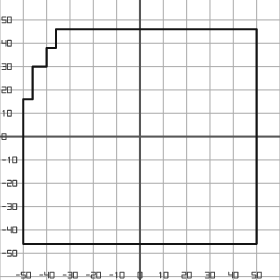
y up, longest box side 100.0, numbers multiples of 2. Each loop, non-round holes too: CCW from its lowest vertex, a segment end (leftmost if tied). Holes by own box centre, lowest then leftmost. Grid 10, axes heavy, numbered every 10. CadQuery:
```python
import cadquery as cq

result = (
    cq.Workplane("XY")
    .moveTo(-50.0, -46.0)
    .lineTo(50.0, -46.0)
    .lineTo(50.0, 46.0)
    .lineTo(-36.0, 46.0)
    .lineTo(-36.0, 38.0)
    .lineTo(-40.0, 38.0)
    .lineTo(-40.0, 30.0)
    .lineTo(-46.0, 30.0)
    .lineTo(-46.0, 16.0)
    .lineTo(-50.0, 16.0)
    .close()
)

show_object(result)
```